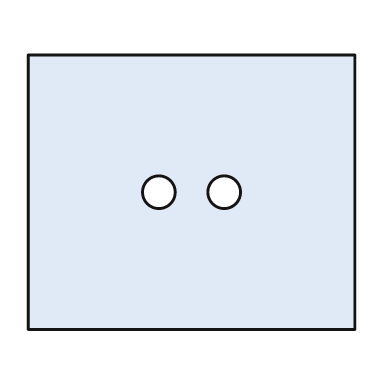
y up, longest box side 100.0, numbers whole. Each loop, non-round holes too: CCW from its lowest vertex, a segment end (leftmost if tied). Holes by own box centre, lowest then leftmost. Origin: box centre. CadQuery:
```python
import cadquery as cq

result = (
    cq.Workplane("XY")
    .moveTo(-50.0, -42.0)
    .lineTo(50.0, -42.0)
    .lineTo(50.0, 42.0)
    .lineTo(-50.0, 42.0)
    .close()
    .moveTo(-10.0, 0.0)
    .circle(5.0)
    .moveTo(10.0, 0.0)
    .circle(5.0)
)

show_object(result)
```